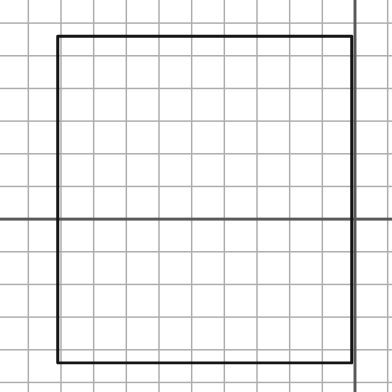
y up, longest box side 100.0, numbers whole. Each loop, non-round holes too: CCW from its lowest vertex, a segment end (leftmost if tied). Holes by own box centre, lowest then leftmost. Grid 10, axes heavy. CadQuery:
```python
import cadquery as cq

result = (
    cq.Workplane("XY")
    .moveTo(-91.0, -44.0)
    .lineTo(-1.0, -44.0)
    .lineTo(-1.0, 56.0)
    .lineTo(-91.0, 56.0)
    .close()
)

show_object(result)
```